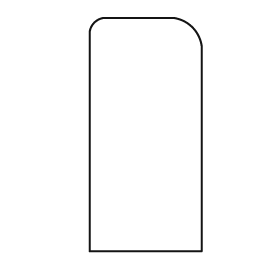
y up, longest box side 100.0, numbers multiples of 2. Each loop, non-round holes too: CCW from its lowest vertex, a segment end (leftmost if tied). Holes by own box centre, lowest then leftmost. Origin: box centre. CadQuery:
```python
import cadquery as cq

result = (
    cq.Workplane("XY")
    .moveTo(-24.0, -50.0)
    .lineTo(24.0, -50.0)
    .lineTo(24.0, 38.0)
    .threePointArc((20.0, 46.0), (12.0, 50.0))
    .lineTo(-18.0, 50.0)
    .threePointArc((-22.0, 48.0), (-24.0, 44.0))
    .close()
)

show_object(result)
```